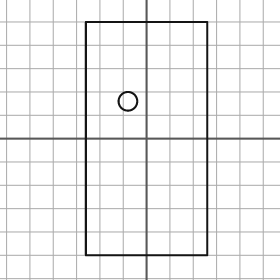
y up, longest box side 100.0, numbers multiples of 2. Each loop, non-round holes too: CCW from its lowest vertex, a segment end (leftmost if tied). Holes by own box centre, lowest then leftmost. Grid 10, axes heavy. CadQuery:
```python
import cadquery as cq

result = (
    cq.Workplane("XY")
    .moveTo(-26.0, -50.0)
    .lineTo(26.0, -50.0)
    .lineTo(26.0, 50.0)
    .lineTo(-26.0, 50.0)
    .close()
    .moveTo(-8.0, 16.0)
    .circle(4.0)
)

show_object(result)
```